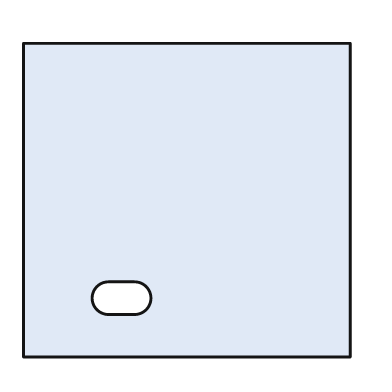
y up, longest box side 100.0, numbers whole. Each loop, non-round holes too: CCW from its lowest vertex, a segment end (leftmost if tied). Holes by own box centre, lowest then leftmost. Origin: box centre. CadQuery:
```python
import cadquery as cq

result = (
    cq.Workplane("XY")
    .moveTo(-50.0, -48.0)
    .lineTo(50.0, -48.0)
    .lineTo(50.0, 48.0)
    .lineTo(-50.0, 48.0)
    .close()
    .moveTo(-24.0, -35.0)
    .lineTo(-16.0, -35.0)
    .threePointArc((-11.0, -30.0), (-16.0, -25.0))
    .lineTo(-24.0, -25.0)
    .threePointArc((-29.0, -30.0), (-24.0, -35.0))
    .close()
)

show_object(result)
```